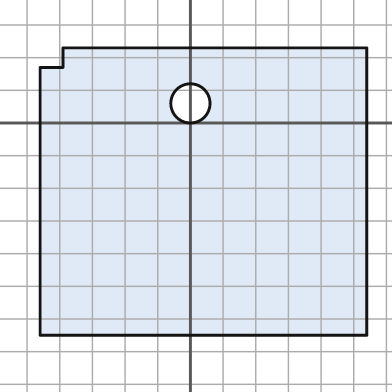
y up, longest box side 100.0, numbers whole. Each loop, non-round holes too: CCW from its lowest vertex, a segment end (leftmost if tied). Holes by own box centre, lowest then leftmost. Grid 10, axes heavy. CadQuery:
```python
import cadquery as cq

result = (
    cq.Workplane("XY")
    .moveTo(-46.0, -65.0)
    .lineTo(54.0, -65.0)
    .lineTo(54.0, 23.0)
    .lineTo(-39.0, 23.0)
    .lineTo(-39.0, 17.0)
    .lineTo(-46.0, 17.0)
    .close()
    .moveTo(0.0, 6.0)
    .circle(6.0)
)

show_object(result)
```